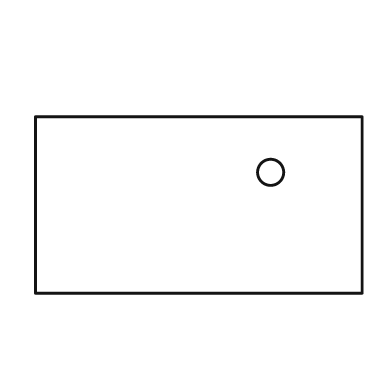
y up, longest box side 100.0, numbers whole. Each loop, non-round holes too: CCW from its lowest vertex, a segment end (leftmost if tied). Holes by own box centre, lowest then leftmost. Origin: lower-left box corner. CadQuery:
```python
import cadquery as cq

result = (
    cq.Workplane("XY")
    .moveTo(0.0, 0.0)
    .lineTo(100.0, 0.0)
    .lineTo(100.0, 54.0)
    .lineTo(0.0, 54.0)
    .close()
    .moveTo(72.0, 37.0)
    .circle(4.0)
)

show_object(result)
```